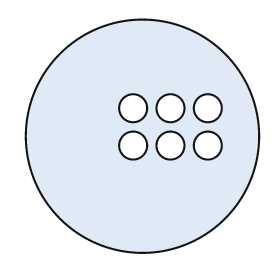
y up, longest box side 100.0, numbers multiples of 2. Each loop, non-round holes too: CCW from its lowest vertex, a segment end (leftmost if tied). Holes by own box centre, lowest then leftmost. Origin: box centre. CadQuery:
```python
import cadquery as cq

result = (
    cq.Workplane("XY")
    .moveTo(0.0, 0.0)
    .circle(50.0)
    .moveTo(-4.0, -4.0)
    .circle(6.0)
    .moveTo(12.0, -4.0)
    .circle(6.0)
    .moveTo(28.0, -4.0)
    .circle(6.0)
    .moveTo(-4.0, 12.0)
    .circle(6.0)
    .moveTo(12.0, 12.0)
    .circle(6.0)
    .moveTo(28.0, 12.0)
    .circle(6.0)
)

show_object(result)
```